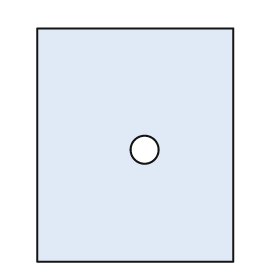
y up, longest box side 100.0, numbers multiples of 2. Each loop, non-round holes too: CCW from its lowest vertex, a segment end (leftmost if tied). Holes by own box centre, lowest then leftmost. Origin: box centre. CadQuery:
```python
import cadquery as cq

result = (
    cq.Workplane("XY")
    .moveTo(-42.0, -50.0)
    .lineTo(42.0, -50.0)
    .lineTo(42.0, 50.0)
    .lineTo(-42.0, 50.0)
    .close()
    .moveTo(4.0, -2.0)
    .circle(6.0)
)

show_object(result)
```